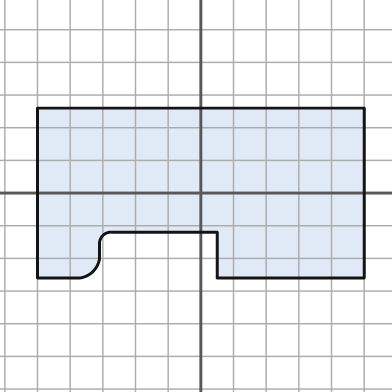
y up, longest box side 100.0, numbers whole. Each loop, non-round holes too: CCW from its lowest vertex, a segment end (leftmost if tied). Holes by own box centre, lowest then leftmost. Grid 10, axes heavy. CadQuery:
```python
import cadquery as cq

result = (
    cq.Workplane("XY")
    .moveTo(-50.0, -26.0)
    .lineTo(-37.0, -26.0)
    .threePointArc((-33.0, -24.0), (-31.0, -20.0))
    .lineTo(-31.0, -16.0)
    .threePointArc((-30.0, -13.0), (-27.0, -12.0))
    .lineTo(5.0, -12.0)
    .lineTo(5.0, -26.0)
    .lineTo(50.0, -26.0)
    .lineTo(50.0, 26.0)
    .lineTo(-50.0, 26.0)
    .close()
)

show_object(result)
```